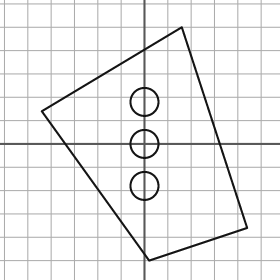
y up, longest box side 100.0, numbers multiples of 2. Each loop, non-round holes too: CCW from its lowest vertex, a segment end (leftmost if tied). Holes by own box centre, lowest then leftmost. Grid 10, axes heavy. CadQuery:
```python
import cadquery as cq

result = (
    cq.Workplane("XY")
    .moveTo(2.0, -50.0)
    .lineTo(44.0, -36.0)
    .lineTo(16.0, 50.0)
    .lineTo(-44.0, 14.0)
    .close()
    .moveTo(0.0, -18.0)
    .circle(6.0)
    .moveTo(0.0, 0.0)
    .circle(6.0)
    .moveTo(0.0, 18.0)
    .circle(6.0)
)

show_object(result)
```